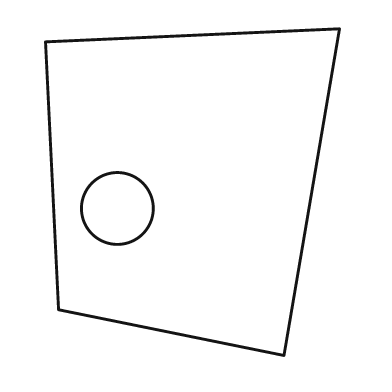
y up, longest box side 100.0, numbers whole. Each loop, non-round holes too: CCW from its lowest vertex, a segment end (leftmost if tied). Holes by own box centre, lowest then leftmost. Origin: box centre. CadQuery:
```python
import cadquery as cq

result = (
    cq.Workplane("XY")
    .moveTo(28.0, -50.0)
    .lineTo(45.0, 50.0)
    .lineTo(-45.0, 46.0)
    .lineTo(-41.0, -36.0)
    .close()
    .moveTo(-23.0, -5.0)
    .circle(11.0)
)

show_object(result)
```